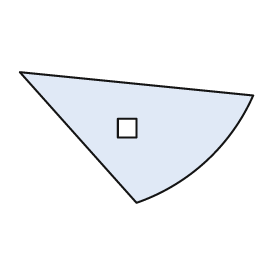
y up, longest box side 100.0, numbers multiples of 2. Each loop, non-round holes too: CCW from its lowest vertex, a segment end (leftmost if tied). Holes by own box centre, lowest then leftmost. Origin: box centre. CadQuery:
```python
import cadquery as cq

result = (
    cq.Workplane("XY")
    .moveTo(0.0, -28.0)
    .threePointArc((30.0, -10.0), (50.0, 18.0))
    .lineTo(-50.0, 28.0)
    .close()
    .moveTo(-8.0, 0.0)
    .lineTo(0.0, 0.0)
    .lineTo(0.0, 8.0)
    .lineTo(-8.0, 8.0)
    .close()
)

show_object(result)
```